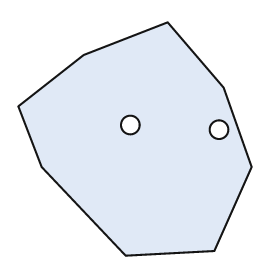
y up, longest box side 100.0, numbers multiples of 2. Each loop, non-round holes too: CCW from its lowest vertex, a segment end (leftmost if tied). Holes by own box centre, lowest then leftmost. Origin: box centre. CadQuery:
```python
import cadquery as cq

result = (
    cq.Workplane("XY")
    .moveTo(-4.0, -50.0)
    .lineTo(34.0, -48.0)
    .lineTo(50.0, -12.0)
    .lineTo(38.0, 22.0)
    .lineTo(14.0, 50.0)
    .lineTo(-22.0, 36.0)
    .lineTo(-50.0, 14.0)
    .lineTo(-40.0, -12.0)
    .close()
    .moveTo(36.0, 4.0)
    .circle(4.0)
    .moveTo(-2.0, 6.0)
    .circle(4.0)
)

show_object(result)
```